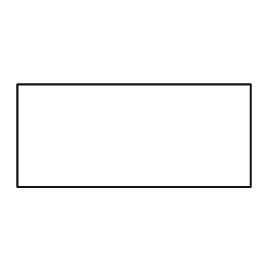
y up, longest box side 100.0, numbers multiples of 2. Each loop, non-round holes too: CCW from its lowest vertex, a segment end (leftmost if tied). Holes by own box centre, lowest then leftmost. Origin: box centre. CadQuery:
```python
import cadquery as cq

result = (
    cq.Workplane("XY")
    .moveTo(-50.0, -22.0)
    .lineTo(50.0, -22.0)
    .lineTo(50.0, 22.0)
    .lineTo(-50.0, 22.0)
    .close()
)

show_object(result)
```